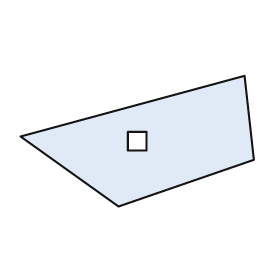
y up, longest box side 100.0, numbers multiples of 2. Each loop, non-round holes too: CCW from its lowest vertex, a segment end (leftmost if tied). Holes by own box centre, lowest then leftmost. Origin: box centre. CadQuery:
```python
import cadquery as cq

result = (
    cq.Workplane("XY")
    .moveTo(-8.0, -28.0)
    .lineTo(50.0, -8.0)
    .lineTo(46.0, 28.0)
    .lineTo(-50.0, 2.0)
    .close()
    .moveTo(-4.0, -4.0)
    .lineTo(4.0, -4.0)
    .lineTo(4.0, 4.0)
    .lineTo(-4.0, 4.0)
    .close()
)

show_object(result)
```